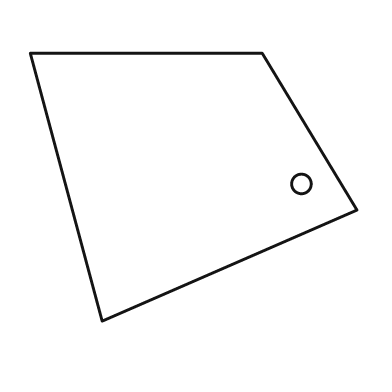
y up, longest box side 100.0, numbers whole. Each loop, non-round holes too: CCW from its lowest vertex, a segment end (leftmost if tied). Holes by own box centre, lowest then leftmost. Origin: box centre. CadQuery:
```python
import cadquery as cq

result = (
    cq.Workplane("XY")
    .moveTo(-28.0, -41.0)
    .lineTo(50.0, -7.0)
    .lineTo(21.0, 41.0)
    .lineTo(-50.0, 41.0)
    .close()
    .moveTo(33.0, 1.0)
    .circle(3.0)
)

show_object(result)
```